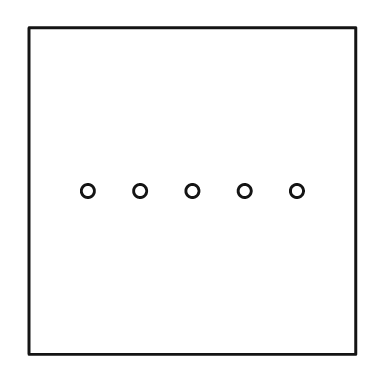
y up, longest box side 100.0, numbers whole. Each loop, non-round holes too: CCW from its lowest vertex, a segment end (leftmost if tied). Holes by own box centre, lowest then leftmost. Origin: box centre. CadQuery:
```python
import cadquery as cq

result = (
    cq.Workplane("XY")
    .moveTo(-50.0, -50.0)
    .lineTo(50.0, -50.0)
    .lineTo(50.0, 50.0)
    .lineTo(-50.0, 50.0)
    .close()
    .moveTo(-32.0, 0.0)
    .circle(2.0)
    .moveTo(-16.0, 0.0)
    .circle(2.0)
    .moveTo(0.0, 0.0)
    .circle(2.0)
    .moveTo(16.0, 0.0)
    .circle(2.0)
    .moveTo(32.0, 0.0)
    .circle(2.0)
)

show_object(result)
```